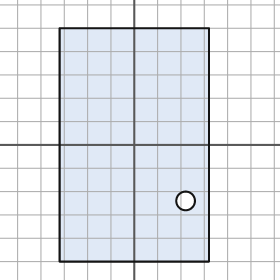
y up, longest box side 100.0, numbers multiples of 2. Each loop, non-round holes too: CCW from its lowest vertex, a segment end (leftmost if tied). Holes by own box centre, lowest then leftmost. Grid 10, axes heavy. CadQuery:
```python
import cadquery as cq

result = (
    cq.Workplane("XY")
    .moveTo(-32.0, -50.0)
    .lineTo(32.0, -50.0)
    .lineTo(32.0, 50.0)
    .lineTo(-32.0, 50.0)
    .close()
    .moveTo(22.0, -24.0)
    .circle(4.0)
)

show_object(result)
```